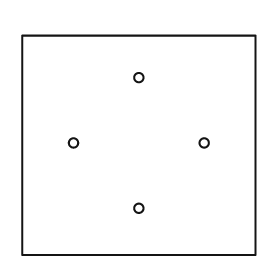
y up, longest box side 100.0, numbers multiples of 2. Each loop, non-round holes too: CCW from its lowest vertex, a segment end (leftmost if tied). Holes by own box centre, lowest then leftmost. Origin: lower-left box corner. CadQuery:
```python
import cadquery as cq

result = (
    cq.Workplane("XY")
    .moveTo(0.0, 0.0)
    .lineTo(100.0, 0.0)
    .lineTo(100.0, 94.0)
    .lineTo(0.0, 94.0)
    .close()
    .moveTo(50.0, 20.0)
    .circle(2.0)
    .moveTo(22.0, 48.0)
    .circle(2.0)
    .moveTo(78.0, 48.0)
    .circle(2.0)
    .moveTo(50.0, 76.0)
    .circle(2.0)
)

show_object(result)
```